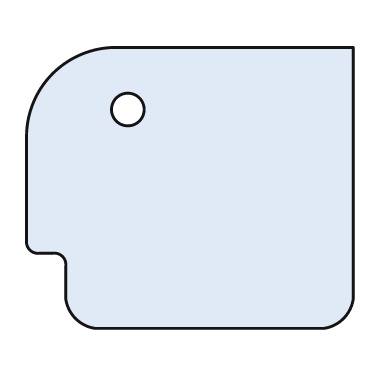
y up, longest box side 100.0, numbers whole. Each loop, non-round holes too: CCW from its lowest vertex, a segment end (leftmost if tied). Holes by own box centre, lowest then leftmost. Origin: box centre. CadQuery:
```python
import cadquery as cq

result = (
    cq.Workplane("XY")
    .moveTo(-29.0, -43.0)
    .lineTo(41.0, -43.0)
    .threePointArc((47.0, -40.0), (50.0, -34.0))
    .lineTo(50.0, 43.0)
    .lineTo(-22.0, 43.0)
    .threePointArc((-42.0, 35.0), (-50.0, 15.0))
    .lineTo(-50.0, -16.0)
    .threePointArc((-49.0, -19.0), (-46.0, -20.0))
    .lineTo(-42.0, -20.0)
    .threePointArc((-39.0, -21.0), (-38.0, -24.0))
    .lineTo(-38.0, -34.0)
    .threePointArc((-35.0, -40.0), (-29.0, -43.0))
    .close()
    .moveTo(-19.0, 24.0)
    .circle(5.0)
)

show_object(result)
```